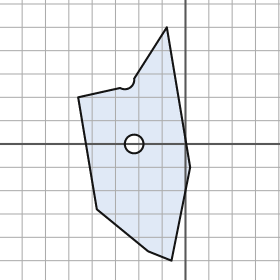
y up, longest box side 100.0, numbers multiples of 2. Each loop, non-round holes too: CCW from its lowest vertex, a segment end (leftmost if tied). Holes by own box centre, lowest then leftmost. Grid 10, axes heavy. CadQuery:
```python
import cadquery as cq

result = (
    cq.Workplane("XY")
    .moveTo(-6.0, -50.0)
    .lineTo(2.0, -10.0)
    .lineTo(-8.0, 50.0)
    .lineTo(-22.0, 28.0)
    .threePointArc((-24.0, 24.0), (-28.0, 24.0))
    .lineTo(-46.0, 20.0)
    .lineTo(-38.0, -28.0)
    .lineTo(-16.0, -46.0)
    .close()
    .moveTo(-22.0, 0.0)
    .circle(4.0)
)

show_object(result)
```